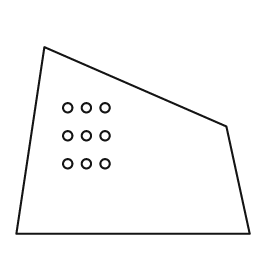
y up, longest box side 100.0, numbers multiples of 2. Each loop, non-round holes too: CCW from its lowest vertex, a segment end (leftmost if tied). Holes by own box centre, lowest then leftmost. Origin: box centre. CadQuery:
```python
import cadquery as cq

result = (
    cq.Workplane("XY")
    .moveTo(-50.0, -40.0)
    .lineTo(50.0, -40.0)
    .lineTo(40.0, 6.0)
    .lineTo(-38.0, 40.0)
    .close()
    .moveTo(-28.0, -10.0)
    .circle(2.0)
    .moveTo(-20.0, -10.0)
    .circle(2.0)
    .moveTo(-12.0, -10.0)
    .circle(2.0)
    .moveTo(-28.0, 2.0)
    .circle(2.0)
    .moveTo(-20.0, 2.0)
    .circle(2.0)
    .moveTo(-12.0, 2.0)
    .circle(2.0)
    .moveTo(-28.0, 14.0)
    .circle(2.0)
    .moveTo(-20.0, 14.0)
    .circle(2.0)
    .moveTo(-12.0, 14.0)
    .circle(2.0)
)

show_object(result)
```